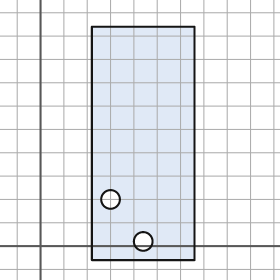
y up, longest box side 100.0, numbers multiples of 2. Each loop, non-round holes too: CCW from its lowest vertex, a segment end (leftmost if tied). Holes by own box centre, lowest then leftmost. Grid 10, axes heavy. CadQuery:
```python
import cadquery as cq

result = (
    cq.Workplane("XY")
    .moveTo(22.0, -6.0)
    .lineTo(66.0, -6.0)
    .lineTo(66.0, 94.0)
    .lineTo(22.0, 94.0)
    .close()
    .moveTo(44.0, 2.0)
    .circle(4.0)
    .moveTo(30.0, 20.0)
    .circle(4.0)
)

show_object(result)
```